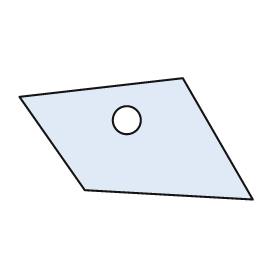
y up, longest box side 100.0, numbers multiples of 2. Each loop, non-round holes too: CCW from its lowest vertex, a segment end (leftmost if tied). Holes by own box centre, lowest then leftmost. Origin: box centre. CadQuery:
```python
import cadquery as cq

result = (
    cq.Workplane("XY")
    .moveTo(50.0, -26.0)
    .lineTo(20.0, 26.0)
    .lineTo(-50.0, 18.0)
    .lineTo(-22.0, -22.0)
    .close()
    .moveTo(-4.0, 8.0)
    .circle(6.0)
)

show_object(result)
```